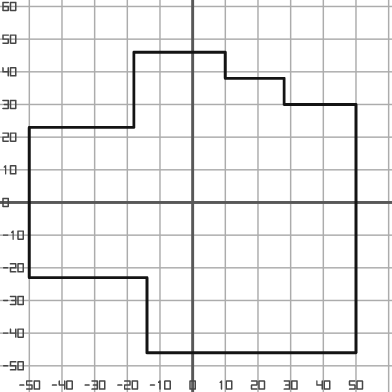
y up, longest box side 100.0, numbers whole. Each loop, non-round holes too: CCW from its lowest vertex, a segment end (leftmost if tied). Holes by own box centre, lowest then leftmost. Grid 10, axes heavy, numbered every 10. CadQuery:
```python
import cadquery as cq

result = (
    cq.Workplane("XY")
    .moveTo(-14.0, -46.0)
    .lineTo(50.0, -46.0)
    .lineTo(50.0, 30.0)
    .lineTo(28.0, 30.0)
    .lineTo(28.0, 38.0)
    .lineTo(10.0, 38.0)
    .lineTo(10.0, 46.0)
    .lineTo(-18.0, 46.0)
    .lineTo(-18.0, 23.0)
    .lineTo(-50.0, 23.0)
    .lineTo(-50.0, -23.0)
    .lineTo(-14.0, -23.0)
    .close()
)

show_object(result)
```